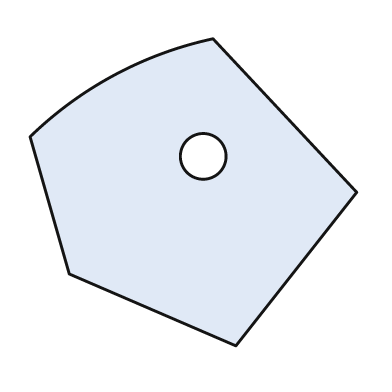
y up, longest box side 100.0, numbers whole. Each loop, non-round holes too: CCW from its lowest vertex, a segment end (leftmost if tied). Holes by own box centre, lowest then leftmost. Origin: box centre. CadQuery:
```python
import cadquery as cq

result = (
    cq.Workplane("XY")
    .moveTo(13.0, -47.0)
    .lineTo(50.0, 0.0)
    .lineTo(6.0, 47.0)
    .threePointArc((-24.0, 36.0), (-50.0, 17.0))
    .lineTo(-38.0, -25.0)
    .close()
    .moveTo(3.0, 11.0)
    .circle(7.0)
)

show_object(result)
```